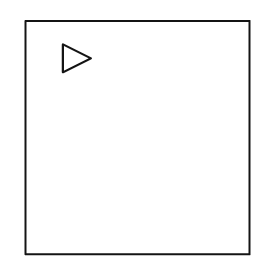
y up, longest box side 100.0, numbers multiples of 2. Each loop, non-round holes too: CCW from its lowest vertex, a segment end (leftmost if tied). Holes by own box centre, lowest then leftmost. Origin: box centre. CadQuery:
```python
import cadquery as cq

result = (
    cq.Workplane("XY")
    .moveTo(-48.0, -50.0)
    .lineTo(48.0, -50.0)
    .lineTo(48.0, 50.0)
    .lineTo(-48.0, 50.0)
    .close()
    .moveTo(-32.0, 28.0)
    .lineTo(-20.0, 34.0)
    .lineTo(-32.0, 40.0)
    .close()
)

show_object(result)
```